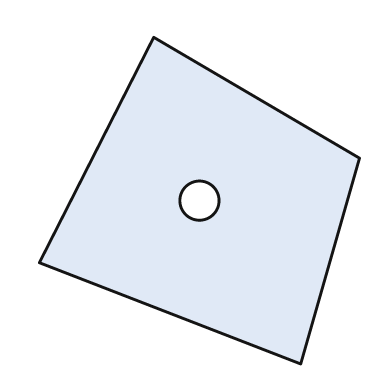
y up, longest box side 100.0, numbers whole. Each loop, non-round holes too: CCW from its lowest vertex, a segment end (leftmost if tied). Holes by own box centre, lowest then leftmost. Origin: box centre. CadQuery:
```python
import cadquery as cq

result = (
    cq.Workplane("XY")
    .moveTo(31.0, -50.0)
    .lineTo(49.0, 13.0)
    .lineTo(-14.0, 50.0)
    .lineTo(-49.0, -19.0)
    .close()
    .moveTo(0.0, 0.0)
    .circle(6.0)
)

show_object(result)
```